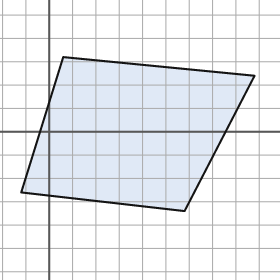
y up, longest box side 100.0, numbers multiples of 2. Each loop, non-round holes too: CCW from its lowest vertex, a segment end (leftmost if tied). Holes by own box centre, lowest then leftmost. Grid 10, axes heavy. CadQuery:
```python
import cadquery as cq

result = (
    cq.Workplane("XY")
    .moveTo(58.0, -34.0)
    .lineTo(88.0, 24.0)
    .lineTo(6.0, 32.0)
    .lineTo(-12.0, -26.0)
    .close()
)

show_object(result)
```